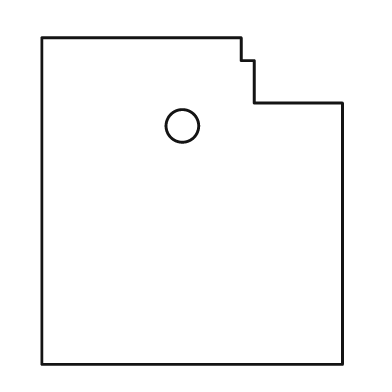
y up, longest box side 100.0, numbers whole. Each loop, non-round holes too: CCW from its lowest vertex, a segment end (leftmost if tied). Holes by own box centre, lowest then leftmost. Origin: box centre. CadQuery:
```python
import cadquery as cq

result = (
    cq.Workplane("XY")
    .moveTo(-46.0, -50.0)
    .lineTo(46.0, -50.0)
    .lineTo(46.0, 30.0)
    .lineTo(19.0, 30.0)
    .lineTo(19.0, 43.0)
    .lineTo(15.0, 43.0)
    .lineTo(15.0, 50.0)
    .lineTo(-46.0, 50.0)
    .close()
    .moveTo(-3.0, 23.0)
    .circle(5.0)
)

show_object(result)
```